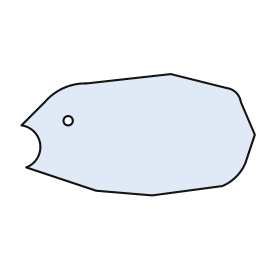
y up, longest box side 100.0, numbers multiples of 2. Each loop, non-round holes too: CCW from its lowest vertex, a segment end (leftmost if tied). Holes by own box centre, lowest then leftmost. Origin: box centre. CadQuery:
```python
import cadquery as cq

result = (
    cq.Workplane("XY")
    .moveTo(6.0, -26.0)
    .lineTo(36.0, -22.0)
    .threePointArc((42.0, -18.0), (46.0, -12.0))
    .lineTo(50.0, 0.0)
    .lineTo(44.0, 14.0)
    .threePointArc((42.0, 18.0), (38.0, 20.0))
    .lineTo(14.0, 26.0)
    .lineTo(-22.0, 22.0)
    .threePointArc((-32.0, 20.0), (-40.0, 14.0))
    .lineTo(-50.0, 4.0)
    .threePointArc((-42.0, -4.0), (-48.0, -14.0))
    .lineTo(-18.0, -24.0)
    .close()
    .moveTo(-30.0, 6.0)
    .circle(2.0)
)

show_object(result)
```